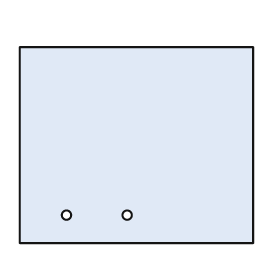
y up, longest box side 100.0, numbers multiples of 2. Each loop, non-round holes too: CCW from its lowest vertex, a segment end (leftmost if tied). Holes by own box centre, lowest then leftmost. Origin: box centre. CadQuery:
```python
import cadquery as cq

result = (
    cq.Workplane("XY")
    .moveTo(-50.0, -42.0)
    .lineTo(50.0, -42.0)
    .lineTo(50.0, 42.0)
    .lineTo(-50.0, 42.0)
    .close()
    .moveTo(-30.0, -30.0)
    .circle(2.0)
    .moveTo(-4.0, -30.0)
    .circle(2.0)
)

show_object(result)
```